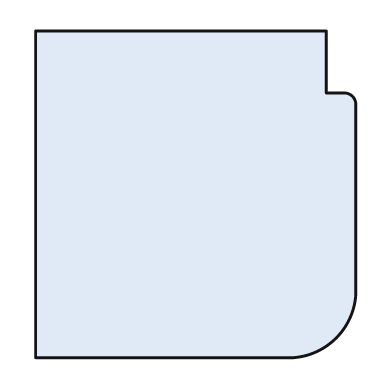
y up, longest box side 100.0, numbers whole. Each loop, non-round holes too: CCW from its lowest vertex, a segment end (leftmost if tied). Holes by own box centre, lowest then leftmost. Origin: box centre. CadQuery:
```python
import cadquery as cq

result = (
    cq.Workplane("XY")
    .moveTo(-49.0, -50.0)
    .lineTo(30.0, -50.0)
    .threePointArc((43.0, -44.0), (49.0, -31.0))
    .lineTo(49.0, 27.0)
    .threePointArc((48.0, 30.0), (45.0, 31.0))
    .lineTo(40.0, 31.0)
    .lineTo(40.0, 50.0)
    .lineTo(-49.0, 50.0)
    .close()
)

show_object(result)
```